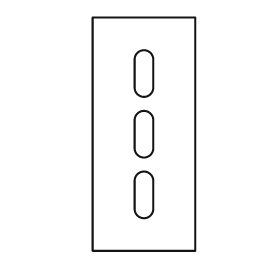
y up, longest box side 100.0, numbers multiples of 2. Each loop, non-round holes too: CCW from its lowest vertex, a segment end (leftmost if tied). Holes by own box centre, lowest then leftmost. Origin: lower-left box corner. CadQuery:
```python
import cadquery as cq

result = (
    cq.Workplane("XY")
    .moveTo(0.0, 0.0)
    .lineTo(44.0, 0.0)
    .lineTo(44.0, 100.0)
    .lineTo(0.0, 100.0)
    .close()
    .moveTo(18.0, 18.0)
    .threePointArc((22.0, 14.0), (26.0, 18.0))
    .lineTo(26.0, 30.0)
    .threePointArc((22.0, 34.0), (18.0, 30.0))
    .close()
    .moveTo(18.0, 44.0)
    .threePointArc((22.0, 40.0), (26.0, 44.0))
    .lineTo(26.0, 56.0)
    .threePointArc((22.0, 60.0), (18.0, 56.0))
    .close()
    .moveTo(18.0, 70.0)
    .threePointArc((22.0, 66.0), (26.0, 70.0))
    .lineTo(26.0, 82.0)
    .threePointArc((22.0, 86.0), (18.0, 82.0))
    .close()
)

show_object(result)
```